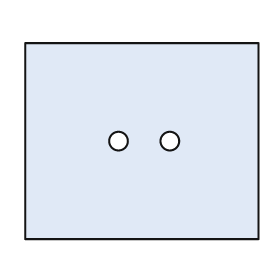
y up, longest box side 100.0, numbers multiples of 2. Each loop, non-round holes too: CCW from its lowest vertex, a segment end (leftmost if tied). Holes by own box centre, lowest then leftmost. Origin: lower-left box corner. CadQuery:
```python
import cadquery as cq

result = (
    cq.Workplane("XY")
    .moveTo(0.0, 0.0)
    .lineTo(100.0, 0.0)
    .lineTo(100.0, 84.0)
    .lineTo(0.0, 84.0)
    .close()
    .moveTo(40.0, 42.0)
    .circle(4.0)
    .moveTo(62.0, 42.0)
    .circle(4.0)
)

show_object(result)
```